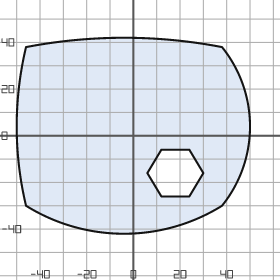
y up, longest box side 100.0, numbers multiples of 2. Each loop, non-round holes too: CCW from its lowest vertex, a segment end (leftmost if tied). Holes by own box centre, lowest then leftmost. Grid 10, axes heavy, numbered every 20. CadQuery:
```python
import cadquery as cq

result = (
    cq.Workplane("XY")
    .moveTo(-46.0, -30.0)
    .threePointArc((-4.0, -42.0), (38.0, -30.0))
    .threePointArc((50.0, 4.0), (38.0, 38.0))
    .threePointArc((-4.0, 42.0), (-46.0, 38.0))
    .threePointArc((-50.0, 4.0), (-46.0, -30.0))
    .close()
    .moveTo(12.0, -26.0)
    .lineTo(24.0, -26.0)
    .lineTo(30.0, -16.0)
    .lineTo(24.0, -6.0)
    .lineTo(12.0, -6.0)
    .lineTo(6.0, -16.0)
    .close()
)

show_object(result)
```